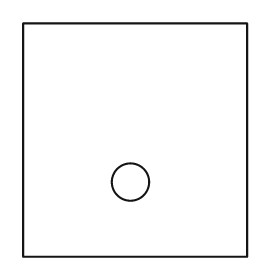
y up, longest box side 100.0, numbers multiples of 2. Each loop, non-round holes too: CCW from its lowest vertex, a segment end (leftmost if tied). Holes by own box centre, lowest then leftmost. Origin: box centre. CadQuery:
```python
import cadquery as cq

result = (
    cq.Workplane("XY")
    .moveTo(-48.0, -50.0)
    .lineTo(48.0, -50.0)
    .lineTo(48.0, 50.0)
    .lineTo(-48.0, 50.0)
    .close()
    .moveTo(-2.0, -18.0)
    .circle(8.0)
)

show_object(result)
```